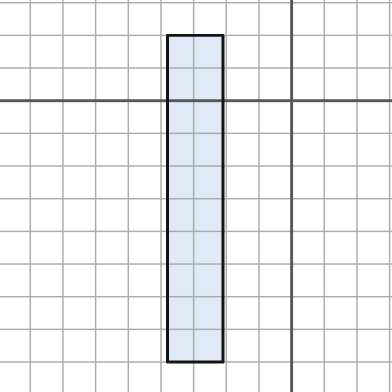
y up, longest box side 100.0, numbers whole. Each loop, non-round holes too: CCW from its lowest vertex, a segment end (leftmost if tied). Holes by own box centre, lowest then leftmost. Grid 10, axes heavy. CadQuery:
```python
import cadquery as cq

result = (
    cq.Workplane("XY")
    .moveTo(-38.0, -80.0)
    .lineTo(-21.0, -80.0)
    .lineTo(-21.0, 20.0)
    .lineTo(-38.0, 20.0)
    .close()
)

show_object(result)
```